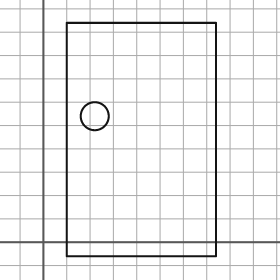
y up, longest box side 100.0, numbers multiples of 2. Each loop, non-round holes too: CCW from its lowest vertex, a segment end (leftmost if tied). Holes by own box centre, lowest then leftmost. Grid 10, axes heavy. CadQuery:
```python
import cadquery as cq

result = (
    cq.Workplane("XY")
    .moveTo(10.0, -6.0)
    .lineTo(74.0, -6.0)
    .lineTo(74.0, 94.0)
    .lineTo(10.0, 94.0)
    .close()
    .moveTo(22.0, 54.0)
    .circle(6.0)
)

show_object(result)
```